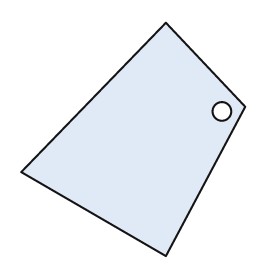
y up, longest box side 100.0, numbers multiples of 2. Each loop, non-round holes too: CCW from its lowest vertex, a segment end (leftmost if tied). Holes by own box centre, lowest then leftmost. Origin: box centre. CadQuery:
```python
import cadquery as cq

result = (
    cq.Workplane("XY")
    .moveTo(14.0, -50.0)
    .lineTo(48.0, 14.0)
    .lineTo(14.0, 50.0)
    .lineTo(-48.0, -14.0)
    .close()
    .moveTo(38.0, 12.0)
    .circle(4.0)
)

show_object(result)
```